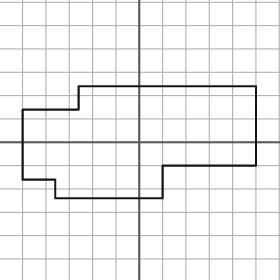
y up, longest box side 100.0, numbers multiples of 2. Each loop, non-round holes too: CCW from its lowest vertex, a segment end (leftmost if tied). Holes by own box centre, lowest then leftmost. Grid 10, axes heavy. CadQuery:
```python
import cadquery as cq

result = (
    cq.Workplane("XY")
    .moveTo(-36.0, -24.0)
    .lineTo(10.0, -24.0)
    .lineTo(10.0, -10.0)
    .lineTo(50.0, -10.0)
    .lineTo(50.0, 24.0)
    .lineTo(-26.0, 24.0)
    .lineTo(-26.0, 14.0)
    .lineTo(-50.0, 14.0)
    .lineTo(-50.0, -16.0)
    .lineTo(-36.0, -16.0)
    .close()
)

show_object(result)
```